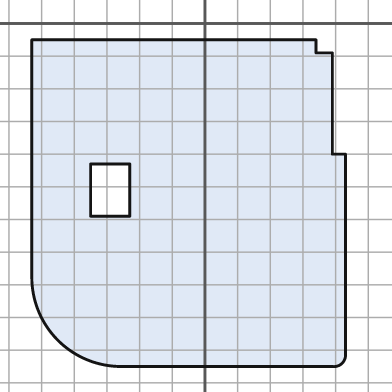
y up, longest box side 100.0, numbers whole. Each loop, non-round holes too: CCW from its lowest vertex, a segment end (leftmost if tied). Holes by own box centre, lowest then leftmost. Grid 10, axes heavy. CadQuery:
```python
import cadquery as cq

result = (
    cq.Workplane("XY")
    .moveTo(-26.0, -105.0)
    .lineTo(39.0, -105.0)
    .threePointArc((42.0, -104.0), (43.0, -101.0))
    .lineTo(43.0, -40.0)
    .lineTo(39.0, -40.0)
    .lineTo(39.0, -9.0)
    .lineTo(34.0, -9.0)
    .lineTo(34.0, -5.0)
    .lineTo(-53.0, -5.0)
    .lineTo(-53.0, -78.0)
    .threePointArc((-45.0, -97.0), (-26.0, -105.0))
    .close()
    .moveTo(-35.0, -59.0)
    .lineTo(-23.0, -59.0)
    .lineTo(-23.0, -43.0)
    .lineTo(-35.0, -43.0)
    .close()
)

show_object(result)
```